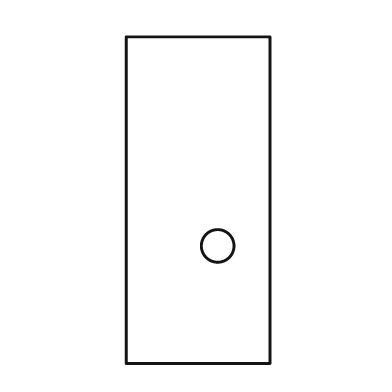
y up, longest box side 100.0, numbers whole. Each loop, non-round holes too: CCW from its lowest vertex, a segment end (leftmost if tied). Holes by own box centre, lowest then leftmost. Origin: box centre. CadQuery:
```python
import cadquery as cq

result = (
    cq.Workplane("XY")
    .moveTo(-22.0, -50.0)
    .lineTo(22.0, -50.0)
    .lineTo(22.0, 50.0)
    .lineTo(-22.0, 50.0)
    .close()
    .moveTo(6.0, -14.0)
    .circle(5.0)
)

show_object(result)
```